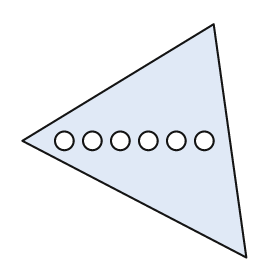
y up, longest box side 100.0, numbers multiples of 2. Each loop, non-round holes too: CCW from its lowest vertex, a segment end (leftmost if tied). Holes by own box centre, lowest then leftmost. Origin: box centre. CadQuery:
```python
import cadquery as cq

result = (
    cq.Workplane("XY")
    .moveTo(48.0, -50.0)
    .lineTo(34.0, 50.0)
    .lineTo(-48.0, 0.0)
    .close()
    .moveTo(-30.0, 0.0)
    .circle(4.0)
    .moveTo(-18.0, 0.0)
    .circle(4.0)
    .moveTo(-6.0, 0.0)
    .circle(4.0)
    .moveTo(6.0, 0.0)
    .circle(4.0)
    .moveTo(18.0, 0.0)
    .circle(4.0)
    .moveTo(30.0, 0.0)
    .circle(4.0)
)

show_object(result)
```